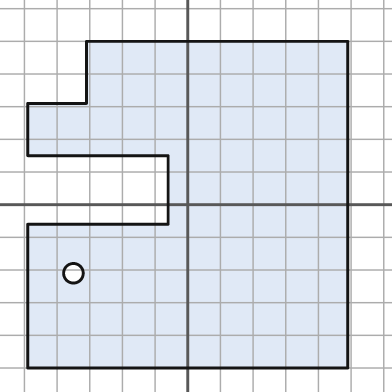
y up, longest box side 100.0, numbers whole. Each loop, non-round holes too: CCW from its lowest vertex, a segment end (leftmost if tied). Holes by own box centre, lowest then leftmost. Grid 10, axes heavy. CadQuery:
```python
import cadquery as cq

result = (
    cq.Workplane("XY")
    .moveTo(-49.0, -50.0)
    .lineTo(49.0, -50.0)
    .lineTo(49.0, 50.0)
    .lineTo(-31.0, 50.0)
    .lineTo(-31.0, 31.0)
    .lineTo(-49.0, 31.0)
    .lineTo(-49.0, 15.0)
    .lineTo(-6.0, 15.0)
    .lineTo(-6.0, -6.0)
    .lineTo(-49.0, -6.0)
    .close()
    .moveTo(-35.0, -21.0)
    .circle(3.0)
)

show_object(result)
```